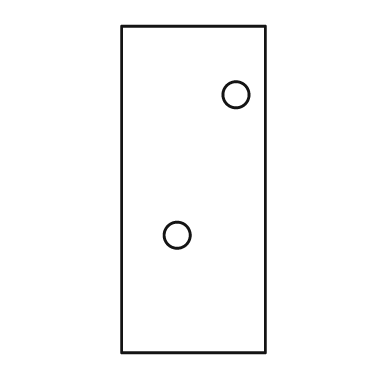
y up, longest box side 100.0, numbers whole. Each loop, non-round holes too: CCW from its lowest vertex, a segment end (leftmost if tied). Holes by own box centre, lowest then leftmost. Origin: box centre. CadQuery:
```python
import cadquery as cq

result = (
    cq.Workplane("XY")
    .moveTo(-22.0, -50.0)
    .lineTo(22.0, -50.0)
    .lineTo(22.0, 50.0)
    .lineTo(-22.0, 50.0)
    .close()
    .moveTo(-5.0, -14.0)
    .circle(4.0)
    .moveTo(13.0, 29.0)
    .circle(4.0)
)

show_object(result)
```